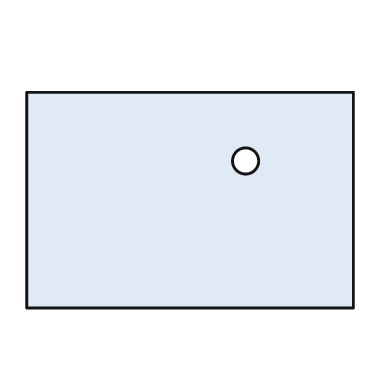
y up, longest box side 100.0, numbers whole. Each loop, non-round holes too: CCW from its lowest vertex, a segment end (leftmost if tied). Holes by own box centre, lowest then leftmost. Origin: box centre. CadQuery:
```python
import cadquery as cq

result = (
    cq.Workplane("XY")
    .moveTo(-50.0, -33.0)
    .lineTo(50.0, -33.0)
    .lineTo(50.0, 33.0)
    .lineTo(-50.0, 33.0)
    .close()
    .moveTo(17.0, 12.0)
    .circle(4.0)
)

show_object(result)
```